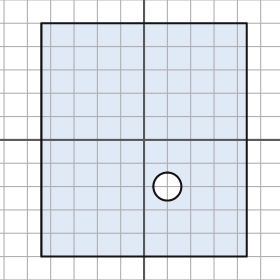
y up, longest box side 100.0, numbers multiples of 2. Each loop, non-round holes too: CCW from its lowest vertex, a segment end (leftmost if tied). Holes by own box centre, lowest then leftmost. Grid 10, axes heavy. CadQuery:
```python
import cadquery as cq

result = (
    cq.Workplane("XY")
    .moveTo(-44.0, -50.0)
    .lineTo(44.0, -50.0)
    .lineTo(44.0, 50.0)
    .lineTo(-44.0, 50.0)
    .close()
    .moveTo(10.0, -20.0)
    .circle(6.0)
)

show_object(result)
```